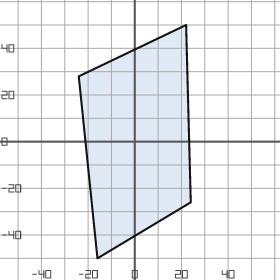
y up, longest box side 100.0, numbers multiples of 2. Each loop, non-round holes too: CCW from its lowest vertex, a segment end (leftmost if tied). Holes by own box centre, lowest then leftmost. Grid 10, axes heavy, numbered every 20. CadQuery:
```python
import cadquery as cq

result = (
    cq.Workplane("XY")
    .moveTo(-16.0, -50.0)
    .lineTo(24.0, -26.0)
    .lineTo(22.0, 50.0)
    .lineTo(-24.0, 28.0)
    .close()
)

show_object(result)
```